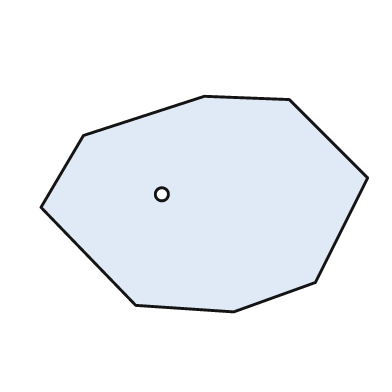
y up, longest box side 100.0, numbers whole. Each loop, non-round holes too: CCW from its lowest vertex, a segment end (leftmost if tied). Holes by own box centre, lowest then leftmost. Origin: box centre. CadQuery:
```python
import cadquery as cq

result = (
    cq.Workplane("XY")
    .moveTo(9.0, -33.0)
    .lineTo(34.0, -24.0)
    .lineTo(50.0, 8.0)
    .lineTo(26.0, 32.0)
    .lineTo(0.0, 33.0)
    .lineTo(-37.0, 21.0)
    .lineTo(-50.0, -1.0)
    .lineTo(-21.0, -31.0)
    .close()
    .moveTo(-13.0, 3.0)
    .circle(2.0)
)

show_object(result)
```